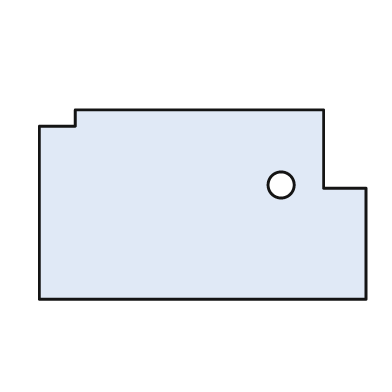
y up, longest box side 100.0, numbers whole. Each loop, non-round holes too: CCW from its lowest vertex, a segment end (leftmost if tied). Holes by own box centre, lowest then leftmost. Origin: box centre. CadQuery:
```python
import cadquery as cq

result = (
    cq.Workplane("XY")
    .moveTo(-50.0, -29.0)
    .lineTo(50.0, -29.0)
    .lineTo(50.0, 5.0)
    .lineTo(37.0, 5.0)
    .lineTo(37.0, 29.0)
    .lineTo(-39.0, 29.0)
    .lineTo(-39.0, 24.0)
    .lineTo(-50.0, 24.0)
    .close()
    .moveTo(24.0, 6.0)
    .circle(4.0)
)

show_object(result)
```